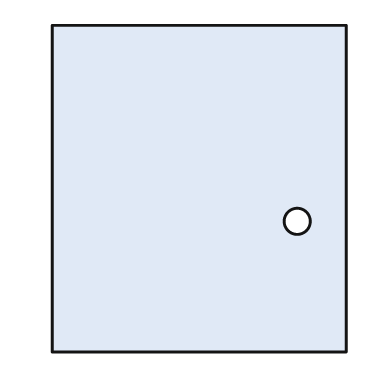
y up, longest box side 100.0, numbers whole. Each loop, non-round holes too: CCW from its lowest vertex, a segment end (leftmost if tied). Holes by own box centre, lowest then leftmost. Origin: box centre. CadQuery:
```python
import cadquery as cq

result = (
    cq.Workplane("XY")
    .moveTo(-45.0, -50.0)
    .lineTo(45.0, -50.0)
    .lineTo(45.0, 50.0)
    .lineTo(-45.0, 50.0)
    .close()
    .moveTo(30.0, -10.0)
    .circle(4.0)
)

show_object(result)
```